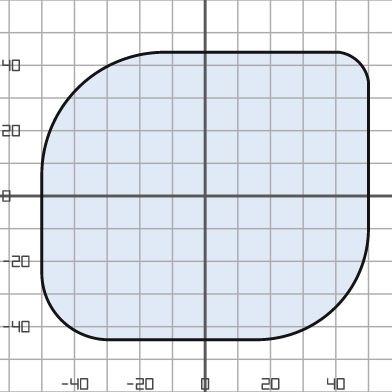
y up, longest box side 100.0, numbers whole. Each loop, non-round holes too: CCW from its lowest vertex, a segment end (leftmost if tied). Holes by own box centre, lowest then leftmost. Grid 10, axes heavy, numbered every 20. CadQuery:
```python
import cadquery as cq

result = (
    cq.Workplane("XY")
    .moveTo(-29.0, -44.0)
    .lineTo(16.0, -44.0)
    .threePointArc((40.0, -34.0), (50.0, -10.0))
    .lineTo(50.0, 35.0)
    .threePointArc((47.0, 41.0), (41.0, 44.0))
    .lineTo(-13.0, 44.0)
    .threePointArc((-39.0, 33.0), (-50.0, 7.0))
    .lineTo(-50.0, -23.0)
    .threePointArc((-44.0, -38.0), (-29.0, -44.0))
    .close()
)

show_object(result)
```